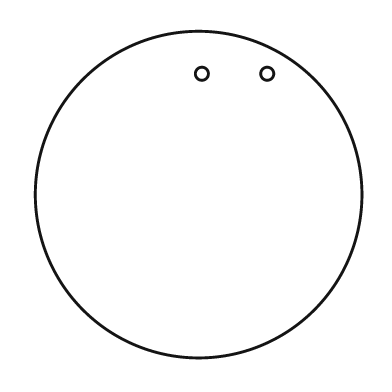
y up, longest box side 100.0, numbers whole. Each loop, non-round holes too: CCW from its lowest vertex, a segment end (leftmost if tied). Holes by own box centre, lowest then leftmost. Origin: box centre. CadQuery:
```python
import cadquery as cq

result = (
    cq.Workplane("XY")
    .moveTo(0.0, 0.0)
    .circle(50.0)
    .moveTo(1.0, 37.0)
    .circle(2.0)
    .moveTo(21.0, 37.0)
    .circle(2.0)
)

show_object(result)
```